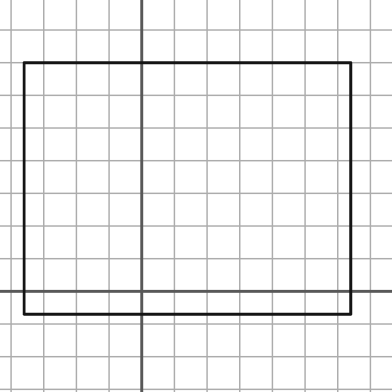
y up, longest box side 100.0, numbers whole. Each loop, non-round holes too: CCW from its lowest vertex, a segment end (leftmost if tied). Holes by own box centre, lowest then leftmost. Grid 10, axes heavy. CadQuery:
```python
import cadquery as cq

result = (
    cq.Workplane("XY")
    .moveTo(-36.0, -7.0)
    .lineTo(64.0, -7.0)
    .lineTo(64.0, 70.0)
    .lineTo(-36.0, 70.0)
    .close()
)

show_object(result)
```